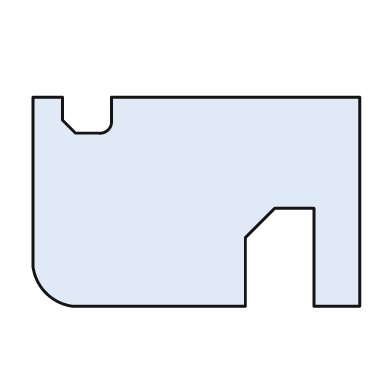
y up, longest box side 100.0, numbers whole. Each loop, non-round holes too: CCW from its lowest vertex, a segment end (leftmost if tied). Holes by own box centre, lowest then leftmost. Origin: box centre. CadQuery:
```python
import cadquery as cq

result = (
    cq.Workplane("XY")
    .moveTo(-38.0, -32.0)
    .lineTo(15.0, -32.0)
    .lineTo(15.0, -11.0)
    .lineTo(24.0, -2.0)
    .lineTo(36.0, -2.0)
    .lineTo(36.0, -32.0)
    .lineTo(50.0, -32.0)
    .lineTo(50.0, 32.0)
    .lineTo(-26.0, 32.0)
    .lineTo(-26.0, 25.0)
    .threePointArc((-27.0, 22.0), (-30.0, 21.0))
    .lineTo(-37.0, 21.0)
    .lineTo(-41.0, 25.0)
    .lineTo(-41.0, 32.0)
    .lineTo(-50.0, 32.0)
    .lineTo(-50.0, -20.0)
    .threePointArc((-46.0, -28.0), (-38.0, -32.0))
    .close()
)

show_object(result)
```